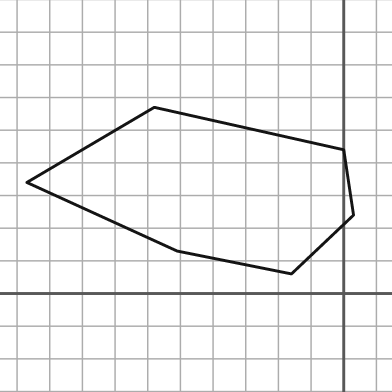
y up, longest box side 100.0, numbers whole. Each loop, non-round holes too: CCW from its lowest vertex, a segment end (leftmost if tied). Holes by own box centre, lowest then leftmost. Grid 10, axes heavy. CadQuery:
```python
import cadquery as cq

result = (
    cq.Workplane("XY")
    .moveTo(-16.0, 6.0)
    .lineTo(3.0, 24.0)
    .lineTo(0.0, 44.0)
    .lineTo(-58.0, 57.0)
    .lineTo(-97.0, 34.0)
    .lineTo(-51.0, 13.0)
    .close()
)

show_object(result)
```